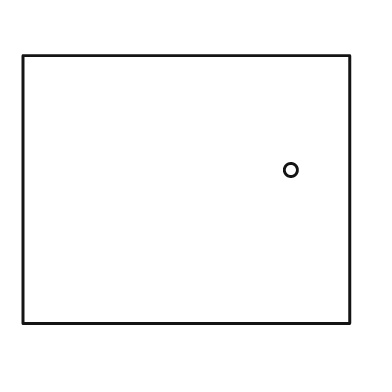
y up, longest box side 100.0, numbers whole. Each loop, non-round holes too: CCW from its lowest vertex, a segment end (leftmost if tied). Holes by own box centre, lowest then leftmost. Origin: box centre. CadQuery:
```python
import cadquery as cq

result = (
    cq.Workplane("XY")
    .moveTo(-50.0, -41.0)
    .lineTo(50.0, -41.0)
    .lineTo(50.0, 41.0)
    .lineTo(-50.0, 41.0)
    .close()
    .moveTo(32.0, 6.0)
    .circle(2.0)
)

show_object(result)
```